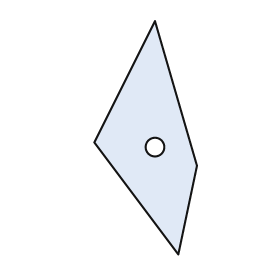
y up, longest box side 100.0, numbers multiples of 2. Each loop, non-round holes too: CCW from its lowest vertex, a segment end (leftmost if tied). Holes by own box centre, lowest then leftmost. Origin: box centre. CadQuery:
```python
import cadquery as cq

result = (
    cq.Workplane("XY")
    .moveTo(14.0, -50.0)
    .lineTo(22.0, -12.0)
    .lineTo(4.0, 50.0)
    .lineTo(-22.0, -2.0)
    .close()
    .moveTo(4.0, -4.0)
    .circle(4.0)
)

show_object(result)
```